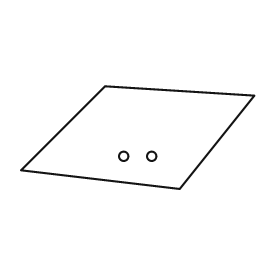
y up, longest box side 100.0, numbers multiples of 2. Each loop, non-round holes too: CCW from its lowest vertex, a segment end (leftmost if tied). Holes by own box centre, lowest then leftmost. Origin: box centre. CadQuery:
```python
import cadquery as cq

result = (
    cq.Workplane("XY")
    .moveTo(18.0, -22.0)
    .lineTo(50.0, 18.0)
    .lineTo(-14.0, 22.0)
    .lineTo(-50.0, -14.0)
    .close()
    .moveTo(-6.0, -8.0)
    .circle(2.0)
    .moveTo(6.0, -8.0)
    .circle(2.0)
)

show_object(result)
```